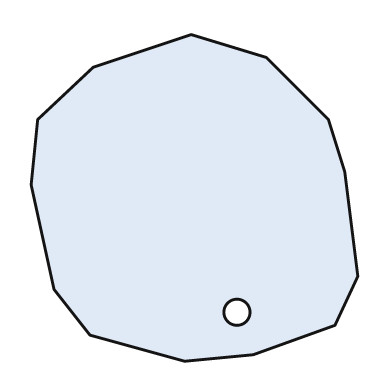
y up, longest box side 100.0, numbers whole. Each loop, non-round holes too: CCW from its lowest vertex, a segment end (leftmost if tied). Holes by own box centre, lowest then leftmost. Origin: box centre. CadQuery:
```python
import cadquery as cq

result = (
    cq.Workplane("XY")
    .moveTo(-3.0, -50.0)
    .lineTo(18.0, -48.0)
    .lineTo(43.0, -39.0)
    .lineTo(50.0, -24.0)
    .lineTo(46.0, 8.0)
    .lineTo(41.0, 24.0)
    .lineTo(22.0, 43.0)
    .lineTo(-1.0, 50.0)
    .lineTo(-31.0, 40.0)
    .lineTo(-48.0, 24.0)
    .lineTo(-50.0, 4.0)
    .lineTo(-43.0, -28.0)
    .lineTo(-32.0, -42.0)
    .close()
    .moveTo(13.0, -35.0)
    .circle(4.0)
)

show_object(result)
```